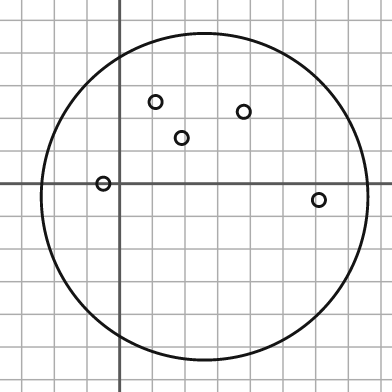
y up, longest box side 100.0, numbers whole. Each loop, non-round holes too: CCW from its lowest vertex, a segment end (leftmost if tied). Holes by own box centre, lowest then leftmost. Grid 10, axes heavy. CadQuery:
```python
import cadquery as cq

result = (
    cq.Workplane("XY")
    .moveTo(26.0, -4.0)
    .circle(50.0)
    .moveTo(61.0, -5.0)
    .circle(2.0)
    .moveTo(-5.0, 0.0)
    .circle(2.0)
    .moveTo(19.0, 14.0)
    .circle(2.0)
    .moveTo(38.0, 22.0)
    .circle(2.0)
    .moveTo(11.0, 25.0)
    .circle(2.0)
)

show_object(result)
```